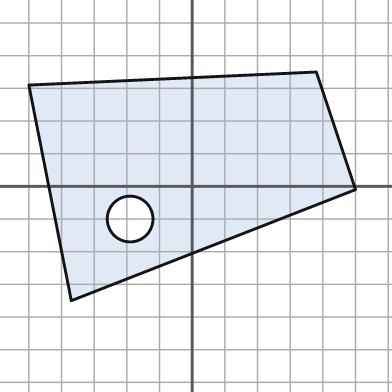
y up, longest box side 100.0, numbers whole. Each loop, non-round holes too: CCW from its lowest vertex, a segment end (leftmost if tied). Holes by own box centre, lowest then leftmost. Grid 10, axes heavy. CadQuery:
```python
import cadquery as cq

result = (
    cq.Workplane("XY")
    .moveTo(-37.0, -35.0)
    .lineTo(50.0, -1.0)
    .lineTo(38.0, 35.0)
    .lineTo(-50.0, 31.0)
    .close()
    .moveTo(-19.0, -10.0)
    .circle(7.0)
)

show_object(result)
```